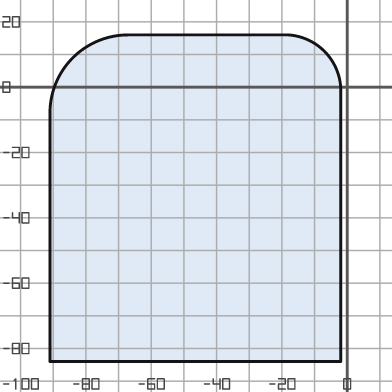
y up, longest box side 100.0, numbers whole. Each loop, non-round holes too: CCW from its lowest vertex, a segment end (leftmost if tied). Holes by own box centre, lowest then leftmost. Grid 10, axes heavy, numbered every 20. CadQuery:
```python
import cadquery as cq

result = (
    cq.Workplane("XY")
    .moveTo(-91.0, -84.0)
    .lineTo(-2.0, -84.0)
    .lineTo(-2.0, 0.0)
    .threePointArc((-7.0, 11.0), (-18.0, 16.0))
    .lineTo(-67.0, 16.0)
    .threePointArc((-84.0, 9.0), (-91.0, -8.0))
    .close()
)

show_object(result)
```